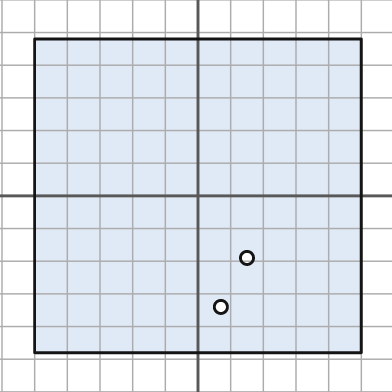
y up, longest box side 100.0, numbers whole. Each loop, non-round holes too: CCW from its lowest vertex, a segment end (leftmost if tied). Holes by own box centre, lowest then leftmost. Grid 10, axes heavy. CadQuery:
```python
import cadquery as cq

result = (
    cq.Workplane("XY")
    .moveTo(-50.0, -48.0)
    .lineTo(50.0, -48.0)
    .lineTo(50.0, 48.0)
    .lineTo(-50.0, 48.0)
    .close()
    .moveTo(7.0, -34.0)
    .circle(2.0)
    .moveTo(15.0, -19.0)
    .circle(2.0)
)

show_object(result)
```